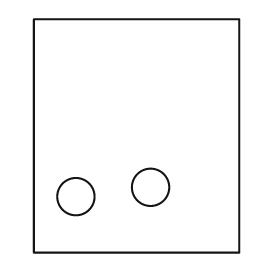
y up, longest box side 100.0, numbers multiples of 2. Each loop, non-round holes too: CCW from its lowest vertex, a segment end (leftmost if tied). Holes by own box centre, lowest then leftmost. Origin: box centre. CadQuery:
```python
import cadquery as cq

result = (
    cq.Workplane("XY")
    .moveTo(-44.0, -50.0)
    .lineTo(44.0, -50.0)
    .lineTo(44.0, 50.0)
    .lineTo(-44.0, 50.0)
    .close()
    .moveTo(-26.0, -26.0)
    .circle(8.0)
    .moveTo(6.0, -22.0)
    .circle(8.0)
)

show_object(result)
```